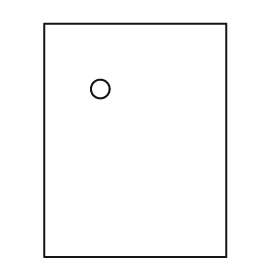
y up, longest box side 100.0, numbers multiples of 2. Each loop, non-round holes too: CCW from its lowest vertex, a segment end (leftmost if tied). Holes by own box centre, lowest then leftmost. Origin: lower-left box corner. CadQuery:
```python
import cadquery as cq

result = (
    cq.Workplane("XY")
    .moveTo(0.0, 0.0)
    .lineTo(78.0, 0.0)
    .lineTo(78.0, 100.0)
    .lineTo(0.0, 100.0)
    .close()
    .moveTo(24.0, 72.0)
    .circle(4.0)
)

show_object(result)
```